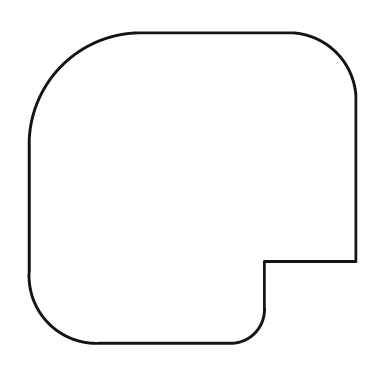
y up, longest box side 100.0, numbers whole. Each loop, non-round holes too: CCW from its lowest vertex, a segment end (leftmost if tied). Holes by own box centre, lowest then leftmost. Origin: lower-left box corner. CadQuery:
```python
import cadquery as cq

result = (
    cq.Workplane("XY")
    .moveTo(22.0, 0.0)
    .lineTo(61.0, 0.0)
    .threePointArc((69.0, 3.0), (72.0, 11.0))
    .lineTo(72.0, 25.0)
    .lineTo(100.0, 25.0)
    .lineTo(100.0, 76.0)
    .threePointArc((94.0, 89.0), (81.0, 95.0))
    .lineTo(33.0, 95.0)
    .threePointArc((10.0, 85.0), (0.0, 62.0))
    .lineTo(0.0, 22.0)
    .threePointArc((6.0, 6.0), (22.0, 0.0))
    .close()
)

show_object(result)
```